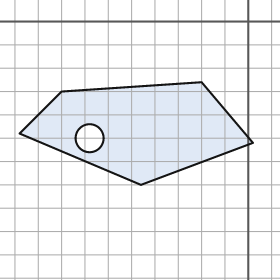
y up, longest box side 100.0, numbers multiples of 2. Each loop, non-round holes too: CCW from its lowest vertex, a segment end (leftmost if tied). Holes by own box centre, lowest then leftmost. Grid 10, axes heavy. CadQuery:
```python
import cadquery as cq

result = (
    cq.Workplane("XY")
    .moveTo(-46.0, -70.0)
    .lineTo(2.0, -52.0)
    .lineTo(-20.0, -26.0)
    .lineTo(-80.0, -30.0)
    .lineTo(-98.0, -48.0)
    .close()
    .moveTo(-68.0, -50.0)
    .circle(6.0)
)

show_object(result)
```